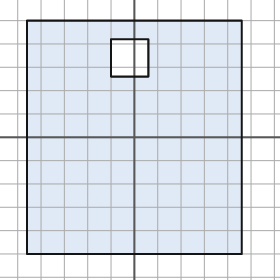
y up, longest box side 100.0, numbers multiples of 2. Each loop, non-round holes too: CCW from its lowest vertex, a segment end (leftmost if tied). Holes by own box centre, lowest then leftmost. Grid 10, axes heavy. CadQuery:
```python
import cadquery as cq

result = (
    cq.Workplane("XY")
    .moveTo(-46.0, -50.0)
    .lineTo(46.0, -50.0)
    .lineTo(46.0, 50.0)
    .lineTo(-46.0, 50.0)
    .close()
    .moveTo(-10.0, 26.0)
    .lineTo(6.0, 26.0)
    .lineTo(6.0, 42.0)
    .lineTo(-10.0, 42.0)
    .close()
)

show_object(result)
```